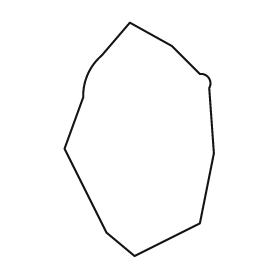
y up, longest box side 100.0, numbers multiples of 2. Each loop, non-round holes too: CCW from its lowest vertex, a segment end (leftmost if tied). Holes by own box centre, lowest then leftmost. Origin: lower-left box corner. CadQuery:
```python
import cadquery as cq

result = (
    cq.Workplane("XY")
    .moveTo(30.0, 0.0)
    .lineTo(58.0, 14.0)
    .lineTo(64.0, 44.0)
    .lineTo(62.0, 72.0)
    .threePointArc((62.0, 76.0), (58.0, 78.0))
    .lineTo(46.0, 90.0)
    .lineTo(28.0, 100.0)
    .lineTo(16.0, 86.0)
    .threePointArc((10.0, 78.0), (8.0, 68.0))
    .lineTo(0.0, 46.0)
    .lineTo(18.0, 10.0)
    .close()
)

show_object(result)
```